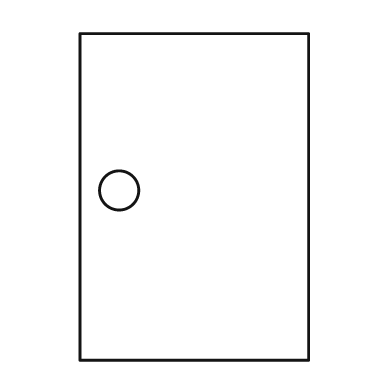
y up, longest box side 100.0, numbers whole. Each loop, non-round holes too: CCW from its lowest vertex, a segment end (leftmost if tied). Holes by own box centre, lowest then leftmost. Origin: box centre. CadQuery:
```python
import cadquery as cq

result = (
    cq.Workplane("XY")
    .moveTo(-35.0, -50.0)
    .lineTo(35.0, -50.0)
    .lineTo(35.0, 50.0)
    .lineTo(-35.0, 50.0)
    .close()
    .moveTo(-23.0, 2.0)
    .circle(6.0)
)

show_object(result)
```